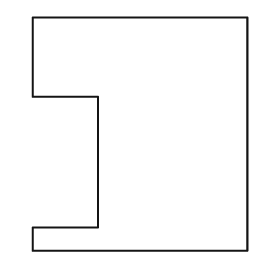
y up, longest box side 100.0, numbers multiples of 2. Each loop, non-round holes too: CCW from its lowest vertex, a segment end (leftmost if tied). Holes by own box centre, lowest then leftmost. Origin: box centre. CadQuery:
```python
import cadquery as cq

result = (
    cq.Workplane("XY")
    .moveTo(-46.0, -50.0)
    .lineTo(46.0, -50.0)
    .lineTo(46.0, 50.0)
    .lineTo(-46.0, 50.0)
    .lineTo(-46.0, 16.0)
    .lineTo(-18.0, 16.0)
    .lineTo(-18.0, -40.0)
    .lineTo(-46.0, -40.0)
    .close()
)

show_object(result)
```